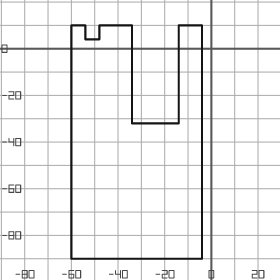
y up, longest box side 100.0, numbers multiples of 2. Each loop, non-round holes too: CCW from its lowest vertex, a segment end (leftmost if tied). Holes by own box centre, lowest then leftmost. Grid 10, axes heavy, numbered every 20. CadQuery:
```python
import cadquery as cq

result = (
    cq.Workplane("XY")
    .moveTo(-60.0, -90.0)
    .lineTo(-4.0, -90.0)
    .lineTo(-4.0, 10.0)
    .lineTo(-14.0, 10.0)
    .lineTo(-14.0, -32.0)
    .lineTo(-34.0, -32.0)
    .lineTo(-34.0, 10.0)
    .lineTo(-48.0, 10.0)
    .lineTo(-48.0, 4.0)
    .lineTo(-54.0, 4.0)
    .lineTo(-54.0, 10.0)
    .lineTo(-60.0, 10.0)
    .close()
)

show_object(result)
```